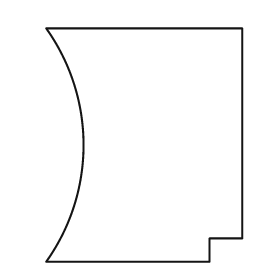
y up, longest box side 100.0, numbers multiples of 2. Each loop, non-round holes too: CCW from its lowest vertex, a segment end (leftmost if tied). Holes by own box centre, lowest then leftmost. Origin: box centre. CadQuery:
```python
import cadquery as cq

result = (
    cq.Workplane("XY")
    .moveTo(-42.0, -50.0)
    .lineTo(28.0, -50.0)
    .lineTo(28.0, -40.0)
    .lineTo(42.0, -40.0)
    .lineTo(42.0, 50.0)
    .lineTo(-42.0, 50.0)
    .threePointArc((-26.0, 0.0), (-42.0, -50.0))
    .close()
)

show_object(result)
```